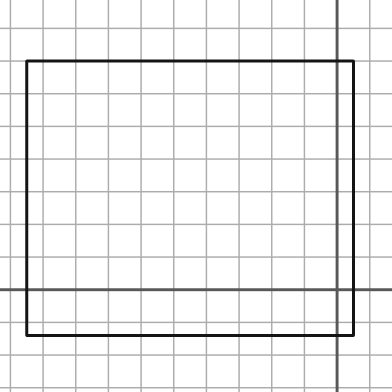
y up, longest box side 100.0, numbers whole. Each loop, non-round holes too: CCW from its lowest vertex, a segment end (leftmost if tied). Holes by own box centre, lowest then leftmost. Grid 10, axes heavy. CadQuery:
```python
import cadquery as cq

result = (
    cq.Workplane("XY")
    .moveTo(-95.0, -14.0)
    .lineTo(5.0, -14.0)
    .lineTo(5.0, 70.0)
    .lineTo(-95.0, 70.0)
    .close()
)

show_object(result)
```